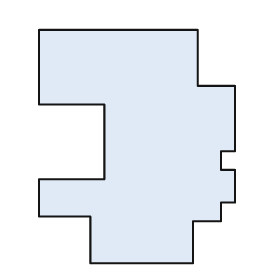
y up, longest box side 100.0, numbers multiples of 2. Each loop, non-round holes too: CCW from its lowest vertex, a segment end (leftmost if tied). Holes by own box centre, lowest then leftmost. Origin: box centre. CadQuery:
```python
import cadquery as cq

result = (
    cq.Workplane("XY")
    .moveTo(-20.0, -50.0)
    .lineTo(24.0, -50.0)
    .lineTo(24.0, -32.0)
    .lineTo(36.0, -32.0)
    .lineTo(36.0, -24.0)
    .lineTo(42.0, -24.0)
    .lineTo(42.0, -10.0)
    .lineTo(36.0, -10.0)
    .lineTo(36.0, -2.0)
    .lineTo(42.0, -2.0)
    .lineTo(42.0, 26.0)
    .lineTo(26.0, 26.0)
    .lineTo(26.0, 50.0)
    .lineTo(-42.0, 50.0)
    .lineTo(-42.0, 18.0)
    .lineTo(-14.0, 18.0)
    .lineTo(-14.0, -14.0)
    .lineTo(-42.0, -14.0)
    .lineTo(-42.0, -30.0)
    .lineTo(-20.0, -30.0)
    .close()
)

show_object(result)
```